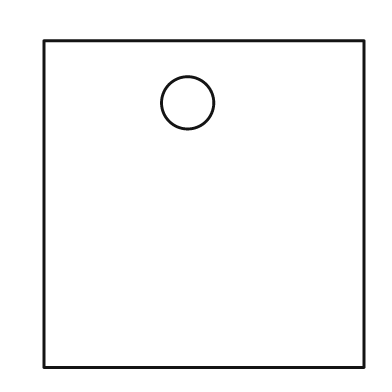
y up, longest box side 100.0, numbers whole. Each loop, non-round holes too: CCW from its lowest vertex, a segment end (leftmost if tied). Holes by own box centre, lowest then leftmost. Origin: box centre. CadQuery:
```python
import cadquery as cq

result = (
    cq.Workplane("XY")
    .moveTo(-49.0, -50.0)
    .lineTo(49.0, -50.0)
    .lineTo(49.0, 50.0)
    .lineTo(-49.0, 50.0)
    .close()
    .moveTo(-5.0, 31.0)
    .circle(8.0)
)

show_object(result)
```